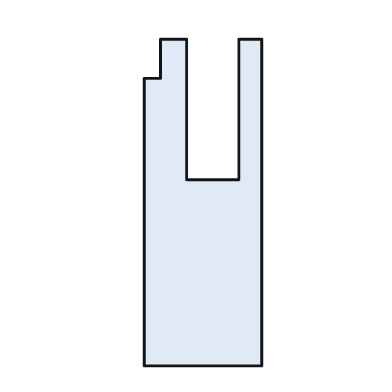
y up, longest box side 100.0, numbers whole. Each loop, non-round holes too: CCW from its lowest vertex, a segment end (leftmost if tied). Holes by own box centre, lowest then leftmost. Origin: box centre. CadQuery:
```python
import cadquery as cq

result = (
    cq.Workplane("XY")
    .moveTo(-18.0, -50.0)
    .lineTo(18.0, -50.0)
    .lineTo(18.0, 50.0)
    .lineTo(11.0, 50.0)
    .lineTo(11.0, 7.0)
    .lineTo(-5.0, 7.0)
    .lineTo(-5.0, 50.0)
    .lineTo(-13.0, 50.0)
    .lineTo(-13.0, 38.0)
    .lineTo(-18.0, 38.0)
    .close()
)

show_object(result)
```